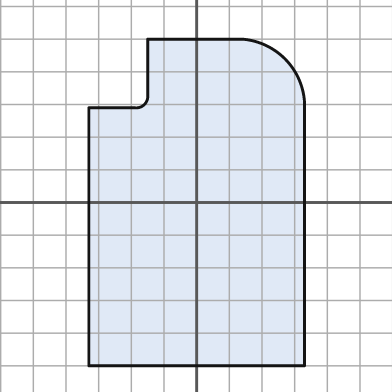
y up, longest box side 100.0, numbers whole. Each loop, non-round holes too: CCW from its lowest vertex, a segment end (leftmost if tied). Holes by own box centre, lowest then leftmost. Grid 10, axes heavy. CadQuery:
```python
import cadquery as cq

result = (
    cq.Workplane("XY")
    .moveTo(-33.0, -50.0)
    .lineTo(33.0, -50.0)
    .lineTo(33.0, 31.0)
    .threePointArc((27.0, 44.0), (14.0, 50.0))
    .lineTo(-15.0, 50.0)
    .lineTo(-15.0, 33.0)
    .threePointArc((-16.0, 30.0), (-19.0, 29.0))
    .lineTo(-33.0, 29.0)
    .close()
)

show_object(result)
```